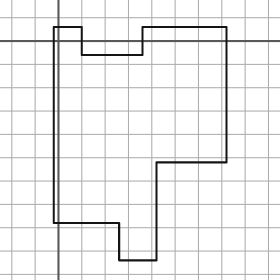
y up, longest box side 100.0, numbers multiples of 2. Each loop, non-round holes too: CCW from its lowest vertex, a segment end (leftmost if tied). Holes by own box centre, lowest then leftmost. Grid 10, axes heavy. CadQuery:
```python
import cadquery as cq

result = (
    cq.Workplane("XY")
    .moveTo(26.0, -94.0)
    .lineTo(42.0, -94.0)
    .lineTo(42.0, -52.0)
    .lineTo(72.0, -52.0)
    .lineTo(72.0, 6.0)
    .lineTo(36.0, 6.0)
    .lineTo(36.0, -6.0)
    .lineTo(10.0, -6.0)
    .lineTo(10.0, 6.0)
    .lineTo(-2.0, 6.0)
    .lineTo(-2.0, -78.0)
    .lineTo(26.0, -78.0)
    .close()
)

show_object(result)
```